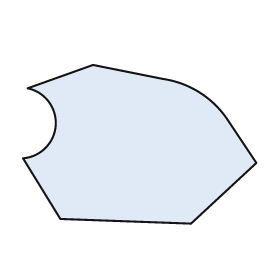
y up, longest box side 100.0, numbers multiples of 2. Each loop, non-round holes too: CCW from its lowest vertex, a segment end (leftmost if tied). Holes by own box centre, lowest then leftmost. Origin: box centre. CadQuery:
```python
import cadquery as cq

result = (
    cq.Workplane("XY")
    .moveTo(22.0, -34.0)
    .lineTo(50.0, -8.0)
    .lineTo(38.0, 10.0)
    .threePointArc((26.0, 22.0), (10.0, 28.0))
    .lineTo(-20.0, 34.0)
    .lineTo(-48.0, 24.0)
    .threePointArc((-36.0, 8.0), (-50.0, -6.0))
    .lineTo(-34.0, -32.0)
    .close()
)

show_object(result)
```